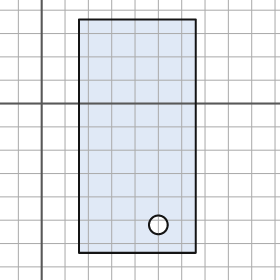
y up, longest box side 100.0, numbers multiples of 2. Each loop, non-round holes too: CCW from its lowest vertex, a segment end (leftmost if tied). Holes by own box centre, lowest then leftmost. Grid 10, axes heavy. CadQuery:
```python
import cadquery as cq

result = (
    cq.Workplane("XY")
    .moveTo(16.0, -64.0)
    .lineTo(66.0, -64.0)
    .lineTo(66.0, 36.0)
    .lineTo(16.0, 36.0)
    .close()
    .moveTo(50.0, -52.0)
    .circle(4.0)
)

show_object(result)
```